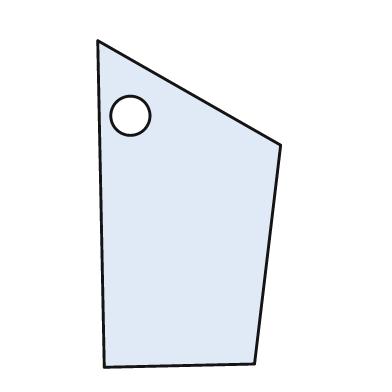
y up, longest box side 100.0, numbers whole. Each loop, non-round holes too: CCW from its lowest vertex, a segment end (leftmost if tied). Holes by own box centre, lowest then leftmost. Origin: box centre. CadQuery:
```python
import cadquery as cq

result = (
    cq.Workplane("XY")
    .moveTo(-26.0, -50.0)
    .lineTo(20.0, -49.0)
    .lineTo(28.0, 18.0)
    .lineTo(-28.0, 50.0)
    .close()
    .moveTo(-18.0, 27.0)
    .circle(6.0)
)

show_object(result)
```